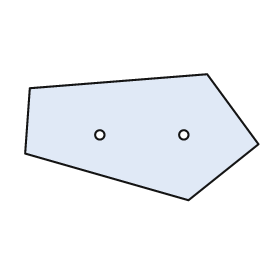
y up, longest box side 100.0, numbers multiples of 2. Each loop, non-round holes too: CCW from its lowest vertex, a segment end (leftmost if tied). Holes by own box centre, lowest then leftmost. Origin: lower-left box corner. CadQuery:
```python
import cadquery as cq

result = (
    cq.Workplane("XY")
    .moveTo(70.0, 0.0)
    .lineTo(100.0, 24.0)
    .lineTo(78.0, 54.0)
    .lineTo(2.0, 48.0)
    .lineTo(0.0, 20.0)
    .close()
    .moveTo(32.0, 28.0)
    .circle(2.0)
    .moveTo(68.0, 28.0)
    .circle(2.0)
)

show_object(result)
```